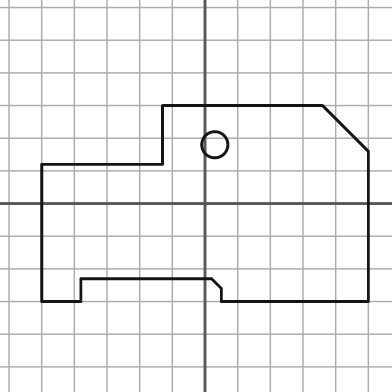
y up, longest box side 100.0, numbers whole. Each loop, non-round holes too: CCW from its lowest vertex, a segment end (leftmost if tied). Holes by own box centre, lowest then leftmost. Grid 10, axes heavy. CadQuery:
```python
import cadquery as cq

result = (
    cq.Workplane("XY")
    .moveTo(-50.0, -30.0)
    .lineTo(-38.0, -30.0)
    .lineTo(-38.0, -23.0)
    .lineTo(2.0, -23.0)
    .lineTo(5.0, -26.0)
    .lineTo(5.0, -30.0)
    .lineTo(50.0, -30.0)
    .lineTo(50.0, 16.0)
    .lineTo(36.0, 30.0)
    .lineTo(-13.0, 30.0)
    .lineTo(-13.0, 12.0)
    .lineTo(-50.0, 12.0)
    .close()
    .moveTo(3.0, 18.0)
    .circle(4.0)
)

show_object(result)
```